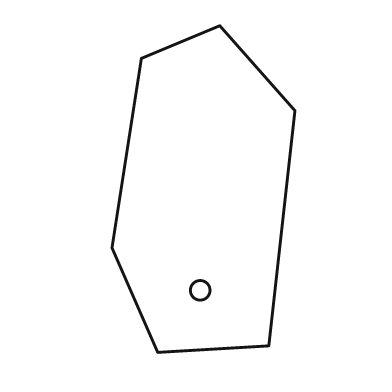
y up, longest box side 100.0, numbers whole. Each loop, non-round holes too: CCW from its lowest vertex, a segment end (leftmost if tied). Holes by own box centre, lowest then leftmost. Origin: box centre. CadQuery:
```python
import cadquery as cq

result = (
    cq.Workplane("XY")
    .moveTo(-14.0, -50.0)
    .lineTo(20.0, -48.0)
    .lineTo(28.0, 24.0)
    .lineTo(5.0, 50.0)
    .lineTo(-19.0, 40.0)
    .lineTo(-28.0, -18.0)
    .close()
    .moveTo(-1.0, -31.0)
    .circle(3.0)
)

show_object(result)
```